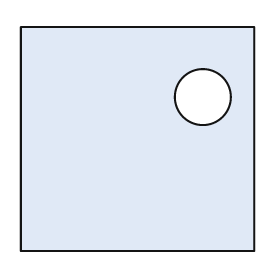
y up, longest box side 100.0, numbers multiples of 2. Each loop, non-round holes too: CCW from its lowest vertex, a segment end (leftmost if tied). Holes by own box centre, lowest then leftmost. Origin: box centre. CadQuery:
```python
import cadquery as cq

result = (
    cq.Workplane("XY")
    .moveTo(-50.0, -48.0)
    .lineTo(50.0, -48.0)
    .lineTo(50.0, 48.0)
    .lineTo(-50.0, 48.0)
    .close()
    .moveTo(28.0, 18.0)
    .circle(12.0)
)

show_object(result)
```